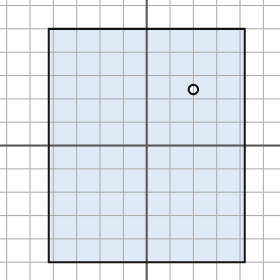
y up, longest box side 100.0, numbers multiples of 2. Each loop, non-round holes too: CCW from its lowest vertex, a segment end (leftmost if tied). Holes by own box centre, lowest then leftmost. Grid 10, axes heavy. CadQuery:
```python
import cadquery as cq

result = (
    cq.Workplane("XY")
    .moveTo(-42.0, -50.0)
    .lineTo(42.0, -50.0)
    .lineTo(42.0, 50.0)
    .lineTo(-42.0, 50.0)
    .close()
    .moveTo(20.0, 24.0)
    .circle(2.0)
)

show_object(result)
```